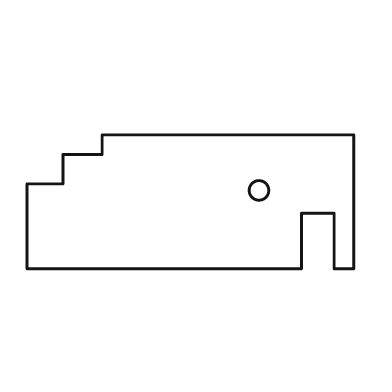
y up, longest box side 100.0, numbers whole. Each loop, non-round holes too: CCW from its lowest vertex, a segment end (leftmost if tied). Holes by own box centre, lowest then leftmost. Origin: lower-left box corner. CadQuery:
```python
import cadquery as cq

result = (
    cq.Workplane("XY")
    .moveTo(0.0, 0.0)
    .lineTo(84.0, 0.0)
    .lineTo(84.0, 17.0)
    .lineTo(94.0, 17.0)
    .lineTo(94.0, 0.0)
    .lineTo(100.0, 0.0)
    .lineTo(100.0, 41.0)
    .lineTo(23.0, 41.0)
    .lineTo(23.0, 35.0)
    .lineTo(11.0, 35.0)
    .lineTo(11.0, 26.0)
    .lineTo(0.0, 26.0)
    .close()
    .moveTo(71.0, 24.0)
    .circle(3.0)
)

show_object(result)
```